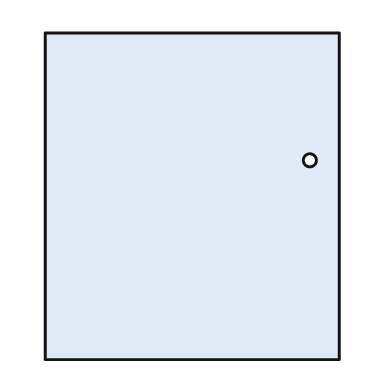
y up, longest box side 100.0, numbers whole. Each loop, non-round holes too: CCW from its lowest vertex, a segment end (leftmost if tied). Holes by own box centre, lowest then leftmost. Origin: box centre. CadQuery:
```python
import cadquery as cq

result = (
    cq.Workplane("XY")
    .moveTo(-45.0, -50.0)
    .lineTo(45.0, -50.0)
    .lineTo(45.0, 50.0)
    .lineTo(-45.0, 50.0)
    .close()
    .moveTo(36.0, 11.0)
    .circle(2.0)
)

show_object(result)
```